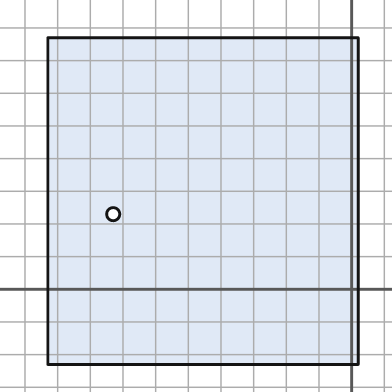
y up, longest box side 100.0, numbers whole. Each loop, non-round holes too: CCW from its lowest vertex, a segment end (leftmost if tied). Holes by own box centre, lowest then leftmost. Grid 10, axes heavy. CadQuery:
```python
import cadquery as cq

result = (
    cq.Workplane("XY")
    .moveTo(-93.0, -23.0)
    .lineTo(2.0, -23.0)
    .lineTo(2.0, 77.0)
    .lineTo(-93.0, 77.0)
    .close()
    .moveTo(-73.0, 23.0)
    .circle(2.0)
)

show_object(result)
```